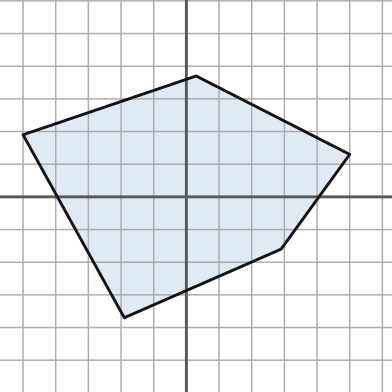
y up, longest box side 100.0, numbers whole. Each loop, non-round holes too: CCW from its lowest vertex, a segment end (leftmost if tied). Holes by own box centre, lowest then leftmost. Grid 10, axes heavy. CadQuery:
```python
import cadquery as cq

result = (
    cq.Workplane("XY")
    .moveTo(-19.0, -37.0)
    .lineTo(29.0, -16.0)
    .lineTo(50.0, 13.0)
    .lineTo(3.0, 37.0)
    .lineTo(-50.0, 19.0)
    .close()
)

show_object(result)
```